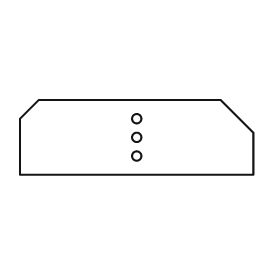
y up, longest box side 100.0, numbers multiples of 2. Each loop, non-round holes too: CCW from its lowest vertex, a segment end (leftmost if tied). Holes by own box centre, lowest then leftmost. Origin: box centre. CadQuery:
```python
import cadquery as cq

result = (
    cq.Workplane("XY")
    .moveTo(-50.0, -16.0)
    .lineTo(50.0, -16.0)
    .lineTo(50.0, 2.0)
    .lineTo(36.0, 16.0)
    .lineTo(-42.0, 16.0)
    .lineTo(-50.0, 8.0)
    .close()
    .moveTo(0.0, -8.0)
    .circle(2.0)
    .moveTo(0.0, 0.0)
    .circle(2.0)
    .moveTo(0.0, 8.0)
    .circle(2.0)
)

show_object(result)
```